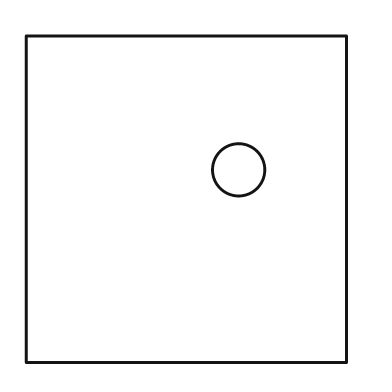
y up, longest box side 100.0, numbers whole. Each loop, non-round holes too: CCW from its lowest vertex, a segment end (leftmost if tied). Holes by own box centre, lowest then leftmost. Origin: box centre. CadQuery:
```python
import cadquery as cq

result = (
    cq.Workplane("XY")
    .moveTo(-49.0, -50.0)
    .lineTo(49.0, -50.0)
    .lineTo(49.0, 50.0)
    .lineTo(-49.0, 50.0)
    .close()
    .moveTo(16.0, 9.0)
    .circle(8.0)
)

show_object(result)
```